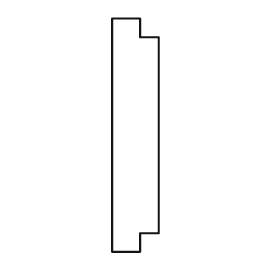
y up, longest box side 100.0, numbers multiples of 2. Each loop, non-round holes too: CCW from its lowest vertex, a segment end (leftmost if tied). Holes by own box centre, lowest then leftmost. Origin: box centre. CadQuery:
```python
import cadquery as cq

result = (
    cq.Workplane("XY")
    .moveTo(-10.0, -50.0)
    .lineTo(2.0, -50.0)
    .lineTo(2.0, -42.0)
    .lineTo(10.0, -42.0)
    .lineTo(10.0, 42.0)
    .lineTo(2.0, 42.0)
    .lineTo(2.0, 50.0)
    .lineTo(-10.0, 50.0)
    .close()
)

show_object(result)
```